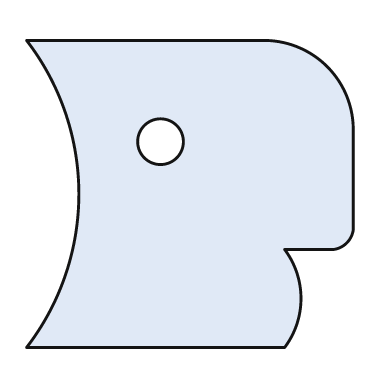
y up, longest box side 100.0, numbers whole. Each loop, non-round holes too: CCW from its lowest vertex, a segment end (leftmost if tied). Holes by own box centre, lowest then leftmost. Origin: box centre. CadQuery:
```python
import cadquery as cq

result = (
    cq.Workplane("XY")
    .moveTo(-50.0, -47.0)
    .lineTo(29.0, -47.0)
    .threePointArc((34.0, -32.0), (29.0, -17.0))
    .lineTo(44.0, -17.0)
    .threePointArc((48.0, -15.0), (50.0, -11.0))
    .lineTo(50.0, 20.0)
    .threePointArc((42.0, 39.0), (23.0, 47.0))
    .lineTo(-50.0, 47.0)
    .threePointArc((-34.0, 0.0), (-50.0, -47.0))
    .close()
    .moveTo(-9.0, 16.0)
    .circle(7.0)
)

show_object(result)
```